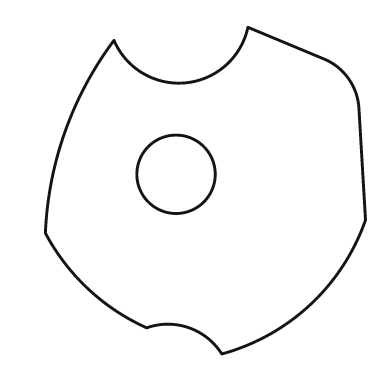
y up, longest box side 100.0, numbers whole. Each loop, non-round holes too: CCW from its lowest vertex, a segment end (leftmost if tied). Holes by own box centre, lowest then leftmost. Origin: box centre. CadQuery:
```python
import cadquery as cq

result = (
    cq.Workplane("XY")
    .moveTo(5.0, -50.0)
    .threePointArc((32.0, -35.0), (49.0, -9.0))
    .lineTo(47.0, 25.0)
    .threePointArc((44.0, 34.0), (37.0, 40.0))
    .lineTo(13.0, 50.0)
    .threePointArc((-6.0, 33.0), (-28.0, 46.0))
    .threePointArc((-43.0, 18.0), (-49.0, -13.0))
    .threePointArc((-36.0, -30.0), (-18.0, -42.0))
    .threePointArc((-5.0, -42.0), (5.0, -50.0))
    .close()
    .moveTo(-9.0, 5.0)
    .circle(12.0)
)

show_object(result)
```